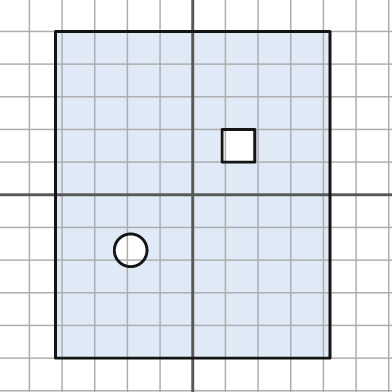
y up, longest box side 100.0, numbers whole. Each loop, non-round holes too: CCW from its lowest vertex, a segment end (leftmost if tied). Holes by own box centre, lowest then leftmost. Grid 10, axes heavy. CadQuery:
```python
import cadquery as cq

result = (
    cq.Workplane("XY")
    .moveTo(-42.0, -50.0)
    .lineTo(42.0, -50.0)
    .lineTo(42.0, 50.0)
    .lineTo(-42.0, 50.0)
    .close()
    .moveTo(-19.0, -17.0)
    .circle(5.0)
    .moveTo(9.0, 10.0)
    .lineTo(19.0, 10.0)
    .lineTo(19.0, 20.0)
    .lineTo(9.0, 20.0)
    .close()
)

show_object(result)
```